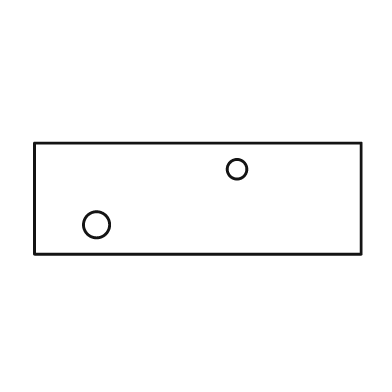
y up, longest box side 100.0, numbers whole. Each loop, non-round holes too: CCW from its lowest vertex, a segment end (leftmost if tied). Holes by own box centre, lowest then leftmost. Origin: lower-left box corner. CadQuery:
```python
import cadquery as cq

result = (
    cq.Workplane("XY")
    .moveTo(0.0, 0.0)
    .lineTo(100.0, 0.0)
    .lineTo(100.0, 34.0)
    .lineTo(0.0, 34.0)
    .close()
    .moveTo(19.0, 9.0)
    .circle(4.0)
    .moveTo(62.0, 26.0)
    .circle(3.0)
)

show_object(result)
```